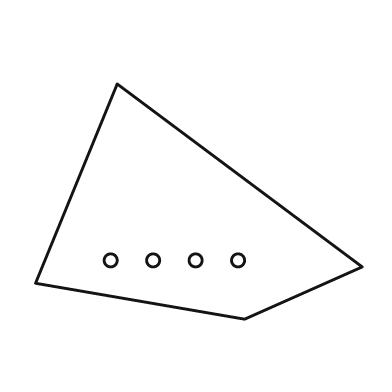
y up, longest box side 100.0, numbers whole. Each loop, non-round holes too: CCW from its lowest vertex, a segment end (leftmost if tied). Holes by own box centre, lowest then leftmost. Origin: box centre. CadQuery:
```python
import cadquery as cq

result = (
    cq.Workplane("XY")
    .moveTo(14.0, -36.0)
    .lineTo(50.0, -20.0)
    .lineTo(-25.0, 36.0)
    .lineTo(-50.0, -25.0)
    .close()
    .moveTo(-27.0, -18.0)
    .circle(2.0)
    .moveTo(-14.0, -18.0)
    .circle(2.0)
    .moveTo(-1.0, -18.0)
    .circle(2.0)
    .moveTo(12.0, -18.0)
    .circle(2.0)
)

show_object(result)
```